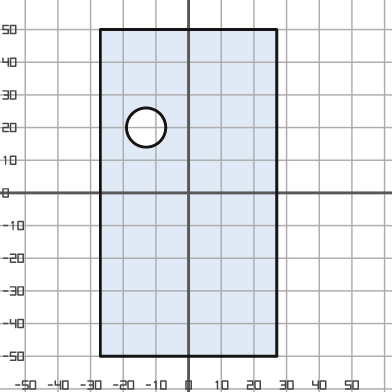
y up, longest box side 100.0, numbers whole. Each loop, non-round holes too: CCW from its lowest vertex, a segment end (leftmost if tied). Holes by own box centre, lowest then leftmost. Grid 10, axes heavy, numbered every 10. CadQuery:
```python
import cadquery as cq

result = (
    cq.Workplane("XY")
    .moveTo(-27.0, -50.0)
    .lineTo(27.0, -50.0)
    .lineTo(27.0, 50.0)
    .lineTo(-27.0, 50.0)
    .close()
    .moveTo(-13.0, 20.0)
    .circle(6.0)
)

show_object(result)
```